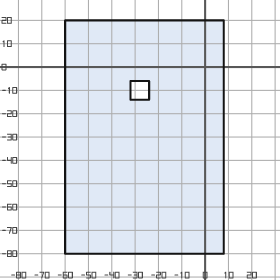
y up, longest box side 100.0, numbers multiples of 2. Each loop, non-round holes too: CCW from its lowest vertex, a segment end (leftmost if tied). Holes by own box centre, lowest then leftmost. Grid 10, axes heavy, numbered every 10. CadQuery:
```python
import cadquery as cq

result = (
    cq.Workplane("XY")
    .moveTo(-60.0, -80.0)
    .lineTo(8.0, -80.0)
    .lineTo(8.0, 20.0)
    .lineTo(-60.0, 20.0)
    .close()
    .moveTo(-32.0, -14.0)
    .lineTo(-24.0, -14.0)
    .lineTo(-24.0, -6.0)
    .lineTo(-32.0, -6.0)
    .close()
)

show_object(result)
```